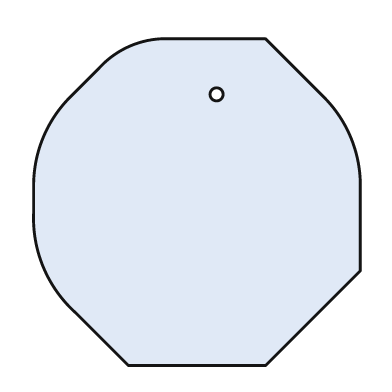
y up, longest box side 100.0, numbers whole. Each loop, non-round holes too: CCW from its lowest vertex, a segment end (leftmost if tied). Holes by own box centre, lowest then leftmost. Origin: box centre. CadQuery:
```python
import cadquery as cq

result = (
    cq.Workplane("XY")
    .moveTo(-21.0, -50.0)
    .lineTo(21.0, -50.0)
    .lineTo(50.0, -21.0)
    .lineTo(50.0, 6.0)
    .threePointArc((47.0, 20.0), (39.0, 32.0))
    .lineTo(21.0, 50.0)
    .lineTo(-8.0, 50.0)
    .threePointArc((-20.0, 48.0), (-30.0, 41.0))
    .lineTo(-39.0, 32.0)
    .threePointArc((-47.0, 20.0), (-50.0, 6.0))
    .lineTo(-50.0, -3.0)
    .threePointArc((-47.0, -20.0), (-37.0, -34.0))
    .close()
    .moveTo(6.0, 33.0)
    .circle(2.0)
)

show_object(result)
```